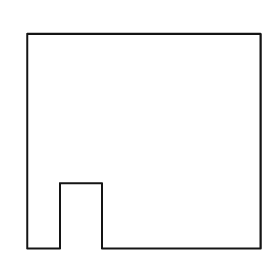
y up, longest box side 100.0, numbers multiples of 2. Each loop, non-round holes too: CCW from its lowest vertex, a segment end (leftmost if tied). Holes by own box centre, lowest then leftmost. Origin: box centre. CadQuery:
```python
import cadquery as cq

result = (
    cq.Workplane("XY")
    .moveTo(-50.0, -46.0)
    .lineTo(-36.0, -46.0)
    .lineTo(-36.0, -18.0)
    .lineTo(-18.0, -18.0)
    .lineTo(-18.0, -46.0)
    .lineTo(50.0, -46.0)
    .lineTo(50.0, 46.0)
    .lineTo(-50.0, 46.0)
    .close()
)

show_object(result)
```